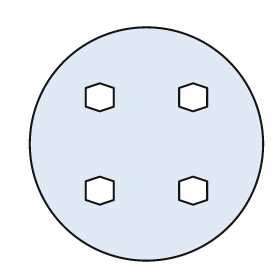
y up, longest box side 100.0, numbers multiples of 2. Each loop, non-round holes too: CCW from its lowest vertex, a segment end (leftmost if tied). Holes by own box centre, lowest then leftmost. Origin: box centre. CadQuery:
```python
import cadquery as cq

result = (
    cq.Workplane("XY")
    .moveTo(0.0, 0.0)
    .circle(50.0)
    .moveTo(-20.0, -26.0)
    .lineTo(-14.0, -24.0)
    .lineTo(-14.0, -16.0)
    .lineTo(-20.0, -14.0)
    .lineTo(-26.0, -16.0)
    .lineTo(-26.0, -24.0)
    .close()
    .moveTo(20.0, -26.0)
    .lineTo(26.0, -24.0)
    .lineTo(26.0, -16.0)
    .lineTo(20.0, -14.0)
    .lineTo(14.0, -16.0)
    .lineTo(14.0, -24.0)
    .close()
    .moveTo(-20.0, 14.0)
    .lineTo(-14.0, 16.0)
    .lineTo(-14.0, 24.0)
    .lineTo(-20.0, 26.0)
    .lineTo(-26.0, 24.0)
    .lineTo(-26.0, 16.0)
    .close()
    .moveTo(20.0, 14.0)
    .lineTo(26.0, 16.0)
    .lineTo(26.0, 24.0)
    .lineTo(20.0, 26.0)
    .lineTo(14.0, 24.0)
    .lineTo(14.0, 16.0)
    .close()
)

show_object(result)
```